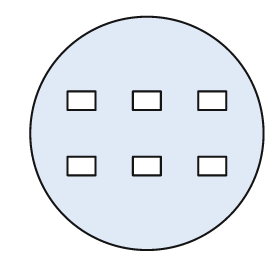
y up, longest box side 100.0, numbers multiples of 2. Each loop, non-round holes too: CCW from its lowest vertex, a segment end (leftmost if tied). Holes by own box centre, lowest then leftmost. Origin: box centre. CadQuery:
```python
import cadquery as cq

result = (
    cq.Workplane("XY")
    .moveTo(0.0, 0.0)
    .circle(50.0)
    .moveTo(-34.0, -18.0)
    .lineTo(-22.0, -18.0)
    .lineTo(-22.0, -10.0)
    .lineTo(-34.0, -10.0)
    .close()
    .moveTo(-6.0, -18.0)
    .lineTo(6.0, -18.0)
    .lineTo(6.0, -10.0)
    .lineTo(-6.0, -10.0)
    .close()
    .moveTo(22.0, -18.0)
    .lineTo(34.0, -18.0)
    .lineTo(34.0, -10.0)
    .lineTo(22.0, -10.0)
    .close()
    .moveTo(-34.0, 10.0)
    .lineTo(-22.0, 10.0)
    .lineTo(-22.0, 18.0)
    .lineTo(-34.0, 18.0)
    .close()
    .moveTo(-6.0, 10.0)
    .lineTo(6.0, 10.0)
    .lineTo(6.0, 18.0)
    .lineTo(-6.0, 18.0)
    .close()
    .moveTo(22.0, 10.0)
    .lineTo(34.0, 10.0)
    .lineTo(34.0, 18.0)
    .lineTo(22.0, 18.0)
    .close()
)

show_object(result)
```